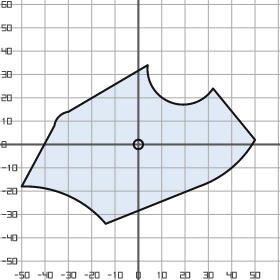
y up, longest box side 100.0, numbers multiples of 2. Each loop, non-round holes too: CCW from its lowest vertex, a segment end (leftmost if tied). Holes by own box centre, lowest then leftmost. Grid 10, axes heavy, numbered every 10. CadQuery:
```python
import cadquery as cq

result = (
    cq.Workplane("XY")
    .moveTo(-14.0, -34.0)
    .lineTo(26.0, -18.0)
    .threePointArc((40.0, -10.0), (50.0, 2.0))
    .lineTo(32.0, 24.0)
    .threePointArc((14.0, 18.0), (4.0, 34.0))
    .lineTo(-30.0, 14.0)
    .threePointArc((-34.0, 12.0), (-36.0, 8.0))
    .lineTo(-50.0, -18.0)
    .threePointArc((-30.0, -22.0), (-14.0, -34.0))
    .close()
    .moveTo(0.0, 0.0)
    .circle(2.0)
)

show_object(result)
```